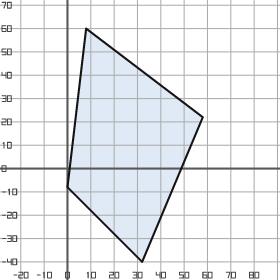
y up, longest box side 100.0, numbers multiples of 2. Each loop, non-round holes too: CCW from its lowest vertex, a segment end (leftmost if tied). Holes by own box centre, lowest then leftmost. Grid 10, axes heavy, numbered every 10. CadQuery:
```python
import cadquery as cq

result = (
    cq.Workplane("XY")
    .moveTo(32.0, -40.0)
    .lineTo(58.0, 22.0)
    .lineTo(8.0, 60.0)
    .lineTo(0.0, -8.0)
    .close()
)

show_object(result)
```